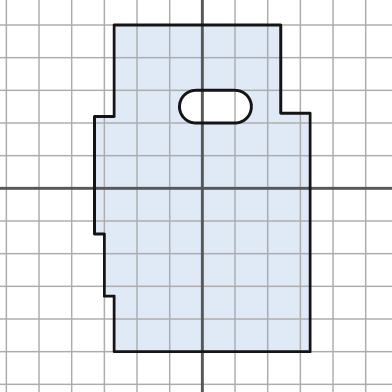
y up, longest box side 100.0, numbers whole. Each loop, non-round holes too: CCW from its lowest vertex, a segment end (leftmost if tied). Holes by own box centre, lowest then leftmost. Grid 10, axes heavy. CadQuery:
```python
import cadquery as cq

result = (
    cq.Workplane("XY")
    .moveTo(-27.0, -50.0)
    .lineTo(33.0, -50.0)
    .lineTo(33.0, 23.0)
    .lineTo(24.0, 23.0)
    .lineTo(24.0, 50.0)
    .lineTo(-27.0, 50.0)
    .lineTo(-27.0, 22.0)
    .lineTo(-33.0, 22.0)
    .lineTo(-33.0, -14.0)
    .lineTo(-30.0, -14.0)
    .lineTo(-30.0, -33.0)
    .lineTo(-27.0, -33.0)
    .close()
    .moveTo(-2.0, 20.0)
    .lineTo(10.0, 20.0)
    .threePointArc((15.0, 25.0), (10.0, 30.0))
    .lineTo(-2.0, 30.0)
    .threePointArc((-7.0, 25.0), (-2.0, 20.0))
    .close()
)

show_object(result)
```